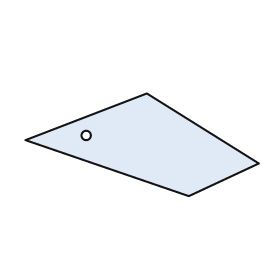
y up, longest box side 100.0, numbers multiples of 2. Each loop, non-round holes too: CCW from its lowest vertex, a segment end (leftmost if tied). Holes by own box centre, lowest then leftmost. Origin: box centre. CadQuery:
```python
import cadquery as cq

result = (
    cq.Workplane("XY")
    .moveTo(20.0, -22.0)
    .lineTo(50.0, -8.0)
    .lineTo(2.0, 22.0)
    .lineTo(-50.0, 2.0)
    .close()
    .moveTo(-24.0, 4.0)
    .circle(2.0)
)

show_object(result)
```